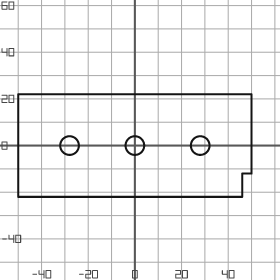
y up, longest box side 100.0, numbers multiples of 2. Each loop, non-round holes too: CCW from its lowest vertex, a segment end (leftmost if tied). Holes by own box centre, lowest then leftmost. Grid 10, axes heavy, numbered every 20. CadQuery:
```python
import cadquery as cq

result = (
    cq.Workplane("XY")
    .moveTo(-50.0, -22.0)
    .lineTo(46.0, -22.0)
    .lineTo(46.0, -12.0)
    .lineTo(50.0, -12.0)
    .lineTo(50.0, 22.0)
    .lineTo(-50.0, 22.0)
    .close()
    .moveTo(-28.0, 0.0)
    .circle(4.0)
    .moveTo(0.0, 0.0)
    .circle(4.0)
    .moveTo(28.0, 0.0)
    .circle(4.0)
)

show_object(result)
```